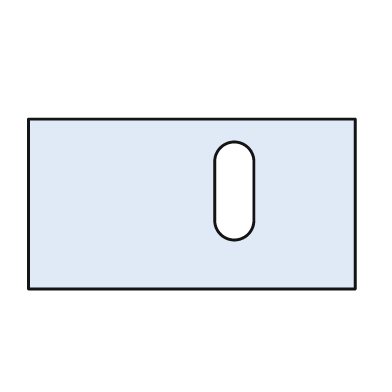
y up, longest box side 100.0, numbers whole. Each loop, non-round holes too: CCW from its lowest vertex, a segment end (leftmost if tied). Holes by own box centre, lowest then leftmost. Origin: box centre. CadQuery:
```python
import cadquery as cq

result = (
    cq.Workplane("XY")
    .moveTo(-50.0, -26.0)
    .lineTo(50.0, -26.0)
    .lineTo(50.0, 26.0)
    .lineTo(-50.0, 26.0)
    .close()
    .moveTo(7.0, -5.0)
    .threePointArc((13.0, -11.0), (19.0, -5.0))
    .lineTo(19.0, 13.0)
    .threePointArc((13.0, 19.0), (7.0, 13.0))
    .close()
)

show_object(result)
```